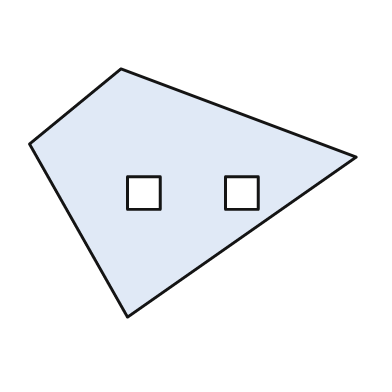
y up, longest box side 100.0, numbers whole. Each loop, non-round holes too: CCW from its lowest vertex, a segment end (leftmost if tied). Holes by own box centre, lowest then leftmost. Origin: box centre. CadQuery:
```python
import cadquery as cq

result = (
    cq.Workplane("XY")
    .moveTo(-20.0, -38.0)
    .lineTo(50.0, 11.0)
    .lineTo(-22.0, 38.0)
    .lineTo(-50.0, 15.0)
    .close()
    .moveTo(-20.0, -5.0)
    .lineTo(-10.0, -5.0)
    .lineTo(-10.0, 5.0)
    .lineTo(-20.0, 5.0)
    .close()
    .moveTo(10.0, -5.0)
    .lineTo(20.0, -5.0)
    .lineTo(20.0, 5.0)
    .lineTo(10.0, 5.0)
    .close()
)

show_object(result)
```